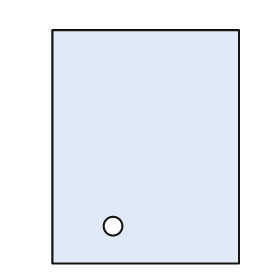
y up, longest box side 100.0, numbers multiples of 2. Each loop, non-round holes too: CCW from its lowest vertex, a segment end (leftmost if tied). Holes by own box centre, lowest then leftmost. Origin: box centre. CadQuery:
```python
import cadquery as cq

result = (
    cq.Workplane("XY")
    .moveTo(-40.0, -50.0)
    .lineTo(40.0, -50.0)
    .lineTo(40.0, 50.0)
    .lineTo(-40.0, 50.0)
    .close()
    .moveTo(-14.0, -34.0)
    .circle(4.0)
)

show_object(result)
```